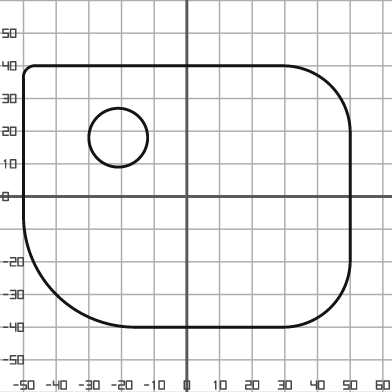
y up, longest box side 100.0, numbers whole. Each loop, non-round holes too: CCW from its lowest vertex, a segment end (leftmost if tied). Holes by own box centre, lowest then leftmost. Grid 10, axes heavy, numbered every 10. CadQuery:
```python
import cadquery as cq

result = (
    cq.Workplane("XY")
    .moveTo(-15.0, -40.0)
    .lineTo(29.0, -40.0)
    .threePointArc((44.0, -34.0), (50.0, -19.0))
    .lineTo(50.0, 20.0)
    .threePointArc((44.0, 34.0), (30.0, 40.0))
    .lineTo(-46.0, 40.0)
    .threePointArc((-49.0, 39.0), (-50.0, 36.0))
    .lineTo(-50.0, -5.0)
    .threePointArc((-40.0, -30.0), (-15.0, -40.0))
    .close()
    .moveTo(-21.0, 18.0)
    .circle(9.0)
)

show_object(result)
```